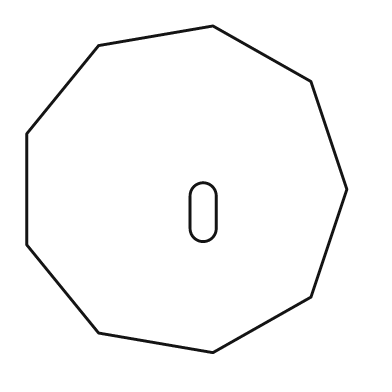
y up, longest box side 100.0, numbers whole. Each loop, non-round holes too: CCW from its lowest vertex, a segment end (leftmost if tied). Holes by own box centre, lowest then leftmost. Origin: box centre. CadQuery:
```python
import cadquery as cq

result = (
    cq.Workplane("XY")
    .moveTo(8.0, -50.0)
    .lineTo(38.0, -33.0)
    .lineTo(49.0, 0.0)
    .lineTo(38.0, 33.0)
    .lineTo(8.0, 50.0)
    .lineTo(-27.0, 44.0)
    .lineTo(-49.0, 17.0)
    .lineTo(-49.0, -17.0)
    .lineTo(-27.0, -44.0)
    .close()
    .moveTo(1.0, -12.0)
    .threePointArc((5.0, -16.0), (9.0, -12.0))
    .lineTo(9.0, -2.0)
    .threePointArc((5.0, 2.0), (1.0, -2.0))
    .close()
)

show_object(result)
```